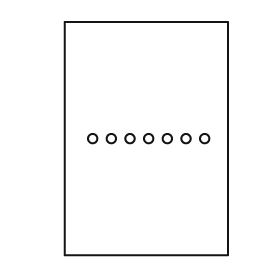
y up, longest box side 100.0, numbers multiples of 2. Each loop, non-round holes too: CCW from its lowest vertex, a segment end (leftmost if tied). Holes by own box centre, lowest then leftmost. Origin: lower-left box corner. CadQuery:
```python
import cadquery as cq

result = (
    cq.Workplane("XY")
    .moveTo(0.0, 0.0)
    .lineTo(70.0, 0.0)
    .lineTo(70.0, 100.0)
    .lineTo(0.0, 100.0)
    .close()
    .moveTo(12.0, 50.0)
    .circle(2.0)
    .moveTo(20.0, 50.0)
    .circle(2.0)
    .moveTo(28.0, 50.0)
    .circle(2.0)
    .moveTo(36.0, 50.0)
    .circle(2.0)
    .moveTo(44.0, 50.0)
    .circle(2.0)
    .moveTo(52.0, 50.0)
    .circle(2.0)
    .moveTo(60.0, 50.0)
    .circle(2.0)
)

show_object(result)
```